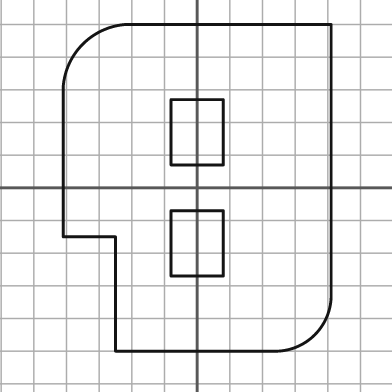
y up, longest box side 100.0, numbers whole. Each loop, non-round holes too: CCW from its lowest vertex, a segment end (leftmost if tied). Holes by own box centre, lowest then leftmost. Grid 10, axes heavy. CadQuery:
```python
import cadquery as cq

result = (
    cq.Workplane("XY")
    .moveTo(-25.0, -50.0)
    .lineTo(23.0, -50.0)
    .threePointArc((36.0, -45.0), (41.0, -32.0))
    .lineTo(41.0, 50.0)
    .lineTo(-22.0, 50.0)
    .threePointArc((-35.0, 44.0), (-41.0, 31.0))
    .lineTo(-41.0, -15.0)
    .lineTo(-25.0, -15.0)
    .close()
    .moveTo(-8.0, -27.0)
    .lineTo(8.0, -27.0)
    .lineTo(8.0, -7.0)
    .lineTo(-8.0, -7.0)
    .close()
    .moveTo(-8.0, 7.0)
    .lineTo(8.0, 7.0)
    .lineTo(8.0, 27.0)
    .lineTo(-8.0, 27.0)
    .close()
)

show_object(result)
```